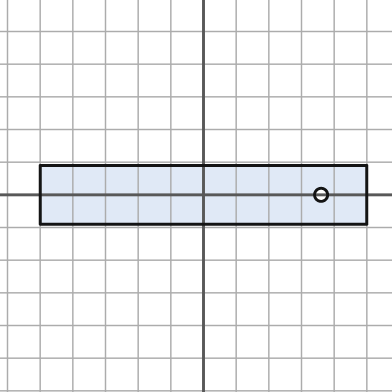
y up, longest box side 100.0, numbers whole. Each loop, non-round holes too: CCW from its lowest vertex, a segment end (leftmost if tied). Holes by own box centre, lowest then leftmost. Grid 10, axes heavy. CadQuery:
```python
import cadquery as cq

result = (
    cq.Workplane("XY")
    .moveTo(-50.0, -9.0)
    .lineTo(50.0, -9.0)
    .lineTo(50.0, 9.0)
    .lineTo(-50.0, 9.0)
    .close()
    .moveTo(36.0, 0.0)
    .circle(2.0)
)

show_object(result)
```